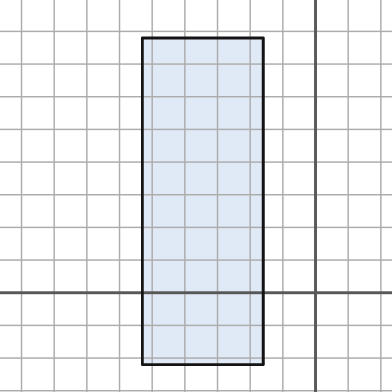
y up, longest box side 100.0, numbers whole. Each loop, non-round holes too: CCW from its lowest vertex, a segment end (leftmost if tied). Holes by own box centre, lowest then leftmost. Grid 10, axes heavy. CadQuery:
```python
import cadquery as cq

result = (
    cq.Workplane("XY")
    .moveTo(-53.0, -22.0)
    .lineTo(-16.0, -22.0)
    .lineTo(-16.0, 78.0)
    .lineTo(-53.0, 78.0)
    .close()
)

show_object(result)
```